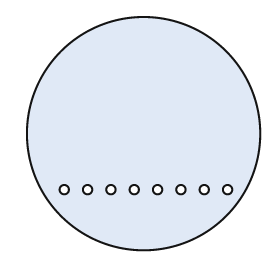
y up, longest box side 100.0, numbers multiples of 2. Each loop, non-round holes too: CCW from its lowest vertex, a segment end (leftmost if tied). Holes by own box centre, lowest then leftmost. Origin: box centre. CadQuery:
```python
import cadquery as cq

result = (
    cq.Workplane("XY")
    .moveTo(0.0, 0.0)
    .circle(50.0)
    .moveTo(-34.0, -24.0)
    .circle(2.0)
    .moveTo(-24.0, -24.0)
    .circle(2.0)
    .moveTo(-14.0, -24.0)
    .circle(2.0)
    .moveTo(-4.0, -24.0)
    .circle(2.0)
    .moveTo(6.0, -24.0)
    .circle(2.0)
    .moveTo(16.0, -24.0)
    .circle(2.0)
    .moveTo(26.0, -24.0)
    .circle(2.0)
    .moveTo(36.0, -24.0)
    .circle(2.0)
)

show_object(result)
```